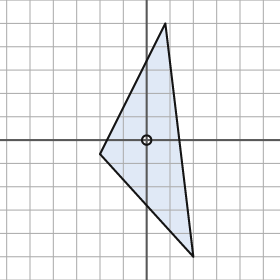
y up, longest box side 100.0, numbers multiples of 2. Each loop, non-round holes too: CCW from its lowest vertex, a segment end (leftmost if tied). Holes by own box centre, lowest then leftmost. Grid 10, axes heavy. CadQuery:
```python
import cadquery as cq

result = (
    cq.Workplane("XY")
    .moveTo(20.0, -50.0)
    .lineTo(8.0, 50.0)
    .lineTo(-20.0, -6.0)
    .close()
    .moveTo(0.0, 0.0)
    .circle(2.0)
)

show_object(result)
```